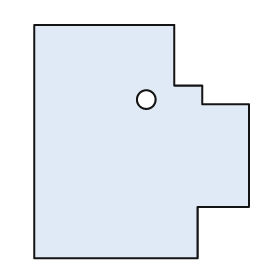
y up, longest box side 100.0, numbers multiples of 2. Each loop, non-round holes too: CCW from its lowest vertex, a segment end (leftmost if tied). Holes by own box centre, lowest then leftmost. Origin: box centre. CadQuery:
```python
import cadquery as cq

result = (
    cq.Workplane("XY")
    .moveTo(-46.0, -50.0)
    .lineTo(24.0, -50.0)
    .lineTo(24.0, -28.0)
    .lineTo(46.0, -28.0)
    .lineTo(46.0, 16.0)
    .lineTo(26.0, 16.0)
    .lineTo(26.0, 24.0)
    .lineTo(14.0, 24.0)
    .lineTo(14.0, 50.0)
    .lineTo(-46.0, 50.0)
    .close()
    .moveTo(2.0, 18.0)
    .circle(4.0)
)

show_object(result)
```